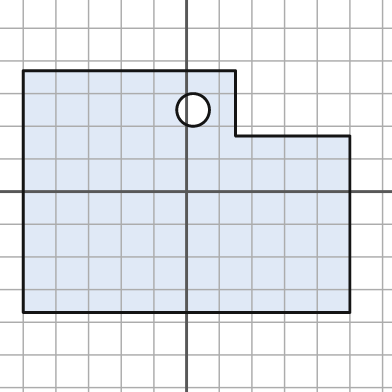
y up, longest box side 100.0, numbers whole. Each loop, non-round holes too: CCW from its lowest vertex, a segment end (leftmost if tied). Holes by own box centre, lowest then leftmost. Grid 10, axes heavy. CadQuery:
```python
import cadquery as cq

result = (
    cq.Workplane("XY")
    .moveTo(-50.0, -37.0)
    .lineTo(50.0, -37.0)
    .lineTo(50.0, 17.0)
    .lineTo(15.0, 17.0)
    .lineTo(15.0, 37.0)
    .lineTo(-50.0, 37.0)
    .close()
    .moveTo(2.0, 25.0)
    .circle(5.0)
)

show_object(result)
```